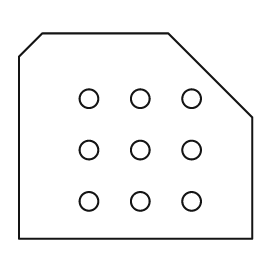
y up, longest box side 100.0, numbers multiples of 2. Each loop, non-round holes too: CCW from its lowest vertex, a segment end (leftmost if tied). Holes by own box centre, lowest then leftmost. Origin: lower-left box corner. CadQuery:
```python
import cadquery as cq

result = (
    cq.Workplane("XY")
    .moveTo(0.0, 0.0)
    .lineTo(100.0, 0.0)
    .lineTo(100.0, 52.0)
    .lineTo(64.0, 88.0)
    .lineTo(10.0, 88.0)
    .lineTo(0.0, 78.0)
    .close()
    .moveTo(30.0, 16.0)
    .circle(4.0)
    .moveTo(52.0, 16.0)
    .circle(4.0)
    .moveTo(74.0, 16.0)
    .circle(4.0)
    .moveTo(30.0, 38.0)
    .circle(4.0)
    .moveTo(52.0, 38.0)
    .circle(4.0)
    .moveTo(74.0, 38.0)
    .circle(4.0)
    .moveTo(30.0, 60.0)
    .circle(4.0)
    .moveTo(52.0, 60.0)
    .circle(4.0)
    .moveTo(74.0, 60.0)
    .circle(4.0)
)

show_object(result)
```